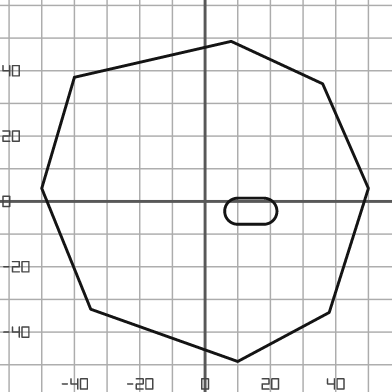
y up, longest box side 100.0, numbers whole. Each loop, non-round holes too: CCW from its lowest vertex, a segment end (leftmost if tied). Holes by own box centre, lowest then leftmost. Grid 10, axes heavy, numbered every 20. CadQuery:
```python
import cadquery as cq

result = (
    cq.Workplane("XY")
    .moveTo(10.0, -49.0)
    .lineTo(38.0, -34.0)
    .lineTo(50.0, 4.0)
    .lineTo(36.0, 36.0)
    .lineTo(8.0, 49.0)
    .lineTo(-40.0, 38.0)
    .lineTo(-50.0, 4.0)
    .lineTo(-35.0, -33.0)
    .close()
    .moveTo(10.0, -7.0)
    .lineTo(18.0, -7.0)
    .threePointArc((22.0, -3.0), (18.0, 1.0))
    .lineTo(10.0, 1.0)
    .threePointArc((6.0, -3.0), (10.0, -7.0))
    .close()
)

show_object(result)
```